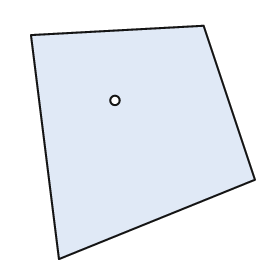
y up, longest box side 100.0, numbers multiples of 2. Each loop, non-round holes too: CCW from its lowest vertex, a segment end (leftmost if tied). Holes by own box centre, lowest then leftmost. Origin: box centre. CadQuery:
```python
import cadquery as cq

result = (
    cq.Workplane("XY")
    .moveTo(-36.0, -50.0)
    .lineTo(48.0, -16.0)
    .lineTo(26.0, 50.0)
    .lineTo(-48.0, 46.0)
    .close()
    .moveTo(-12.0, 18.0)
    .circle(2.0)
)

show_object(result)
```